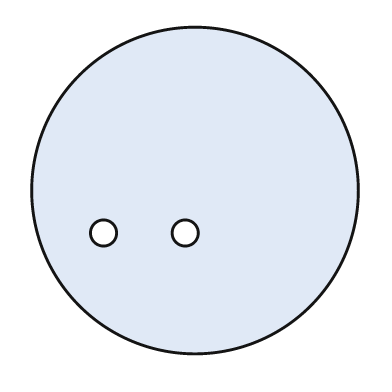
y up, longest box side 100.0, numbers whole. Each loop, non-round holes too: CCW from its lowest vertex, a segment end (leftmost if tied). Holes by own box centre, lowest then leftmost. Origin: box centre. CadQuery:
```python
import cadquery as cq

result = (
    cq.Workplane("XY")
    .moveTo(0.0, 0.0)
    .circle(50.0)
    .moveTo(-28.0, -13.0)
    .circle(4.0)
    .moveTo(-3.0, -13.0)
    .circle(4.0)
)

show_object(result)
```